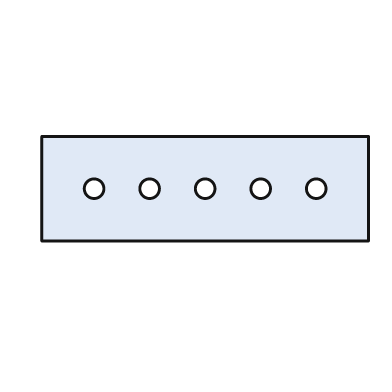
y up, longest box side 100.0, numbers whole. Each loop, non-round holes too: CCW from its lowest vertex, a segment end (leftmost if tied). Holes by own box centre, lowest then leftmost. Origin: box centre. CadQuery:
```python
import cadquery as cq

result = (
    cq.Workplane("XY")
    .moveTo(-50.0, -16.0)
    .lineTo(50.0, -16.0)
    .lineTo(50.0, 16.0)
    .lineTo(-50.0, 16.0)
    .close()
    .moveTo(-34.0, 0.0)
    .circle(3.0)
    .moveTo(-17.0, 0.0)
    .circle(3.0)
    .moveTo(0.0, 0.0)
    .circle(3.0)
    .moveTo(17.0, 0.0)
    .circle(3.0)
    .moveTo(34.0, 0.0)
    .circle(3.0)
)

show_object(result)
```